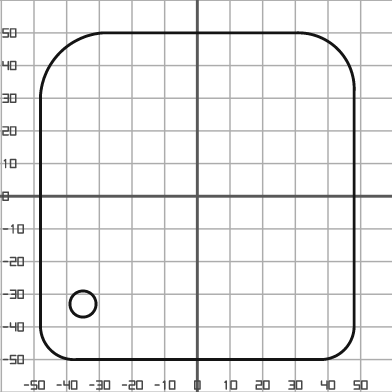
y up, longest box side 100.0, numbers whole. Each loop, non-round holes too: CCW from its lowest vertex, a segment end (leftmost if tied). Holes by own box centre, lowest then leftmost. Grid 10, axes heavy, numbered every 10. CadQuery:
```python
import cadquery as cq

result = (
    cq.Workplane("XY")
    .moveTo(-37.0, -50.0)
    .lineTo(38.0, -50.0)
    .threePointArc((45.0, -47.0), (48.0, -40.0))
    .lineTo(48.0, 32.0)
    .threePointArc((43.0, 45.0), (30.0, 50.0))
    .lineTo(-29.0, 50.0)
    .threePointArc((-42.0, 44.0), (-48.0, 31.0))
    .lineTo(-48.0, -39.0)
    .threePointArc((-45.0, -47.0), (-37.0, -50.0))
    .close()
    .moveTo(-35.0, -33.0)
    .circle(4.0)
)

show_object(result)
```